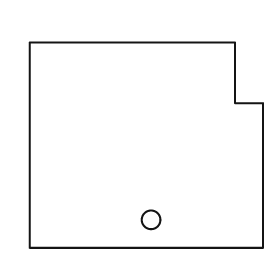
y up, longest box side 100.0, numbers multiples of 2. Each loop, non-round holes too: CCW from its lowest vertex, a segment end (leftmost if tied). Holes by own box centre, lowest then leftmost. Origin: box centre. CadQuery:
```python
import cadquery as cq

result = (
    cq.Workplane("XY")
    .moveTo(-50.0, -44.0)
    .lineTo(50.0, -44.0)
    .lineTo(50.0, 18.0)
    .lineTo(38.0, 18.0)
    .lineTo(38.0, 44.0)
    .lineTo(-50.0, 44.0)
    .close()
    .moveTo(2.0, -32.0)
    .circle(4.0)
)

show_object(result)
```